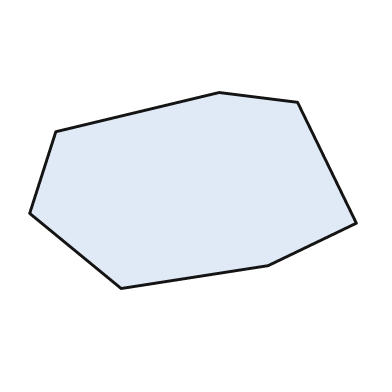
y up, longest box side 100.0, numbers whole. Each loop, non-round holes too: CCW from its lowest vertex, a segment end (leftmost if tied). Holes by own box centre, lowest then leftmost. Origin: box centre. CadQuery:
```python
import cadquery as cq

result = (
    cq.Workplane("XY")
    .moveTo(-22.0, -30.0)
    .lineTo(23.0, -23.0)
    .lineTo(50.0, -10.0)
    .lineTo(32.0, 27.0)
    .lineTo(8.0, 30.0)
    .lineTo(-42.0, 18.0)
    .lineTo(-50.0, -7.0)
    .close()
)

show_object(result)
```